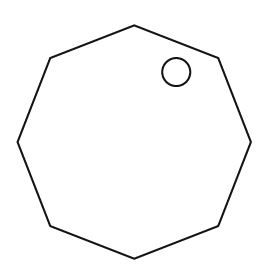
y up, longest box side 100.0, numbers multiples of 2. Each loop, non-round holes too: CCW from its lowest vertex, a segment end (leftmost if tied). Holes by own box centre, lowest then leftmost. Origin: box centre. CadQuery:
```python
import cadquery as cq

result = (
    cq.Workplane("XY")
    .moveTo(0.0, -50.0)
    .lineTo(36.0, -36.0)
    .lineTo(50.0, 0.0)
    .lineTo(36.0, 36.0)
    .lineTo(0.0, 50.0)
    .lineTo(-36.0, 36.0)
    .lineTo(-50.0, 0.0)
    .lineTo(-36.0, -36.0)
    .close()
    .moveTo(18.0, 30.0)
    .circle(6.0)
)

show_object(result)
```